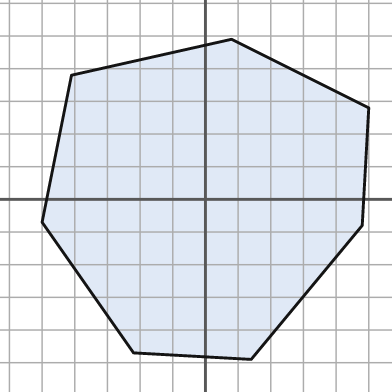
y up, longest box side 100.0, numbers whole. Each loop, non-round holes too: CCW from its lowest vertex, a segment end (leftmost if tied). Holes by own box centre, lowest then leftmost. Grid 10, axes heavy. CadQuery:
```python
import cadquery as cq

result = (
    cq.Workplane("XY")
    .moveTo(14.0, -49.0)
    .lineTo(48.0, -8.0)
    .lineTo(50.0, 28.0)
    .lineTo(8.0, 49.0)
    .lineTo(-41.0, 38.0)
    .lineTo(-50.0, -7.0)
    .lineTo(-22.0, -47.0)
    .close()
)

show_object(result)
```